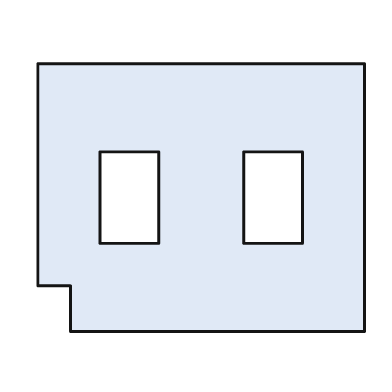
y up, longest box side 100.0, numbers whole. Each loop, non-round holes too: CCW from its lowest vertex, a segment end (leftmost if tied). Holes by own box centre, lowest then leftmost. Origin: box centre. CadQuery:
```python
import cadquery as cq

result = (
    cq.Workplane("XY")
    .moveTo(-40.0, -41.0)
    .lineTo(50.0, -41.0)
    .lineTo(50.0, 41.0)
    .lineTo(-50.0, 41.0)
    .lineTo(-50.0, -27.0)
    .lineTo(-40.0, -27.0)
    .close()
    .moveTo(-31.0, -14.0)
    .lineTo(-13.0, -14.0)
    .lineTo(-13.0, 14.0)
    .lineTo(-31.0, 14.0)
    .close()
    .moveTo(13.0, -14.0)
    .lineTo(31.0, -14.0)
    .lineTo(31.0, 14.0)
    .lineTo(13.0, 14.0)
    .close()
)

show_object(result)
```